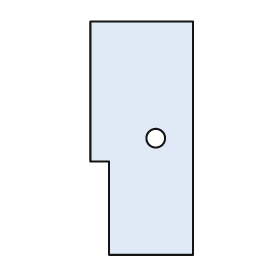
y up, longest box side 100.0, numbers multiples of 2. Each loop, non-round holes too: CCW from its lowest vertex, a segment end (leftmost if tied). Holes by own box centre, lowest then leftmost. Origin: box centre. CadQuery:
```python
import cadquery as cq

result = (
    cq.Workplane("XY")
    .moveTo(-14.0, -50.0)
    .lineTo(22.0, -50.0)
    .lineTo(22.0, 50.0)
    .lineTo(-22.0, 50.0)
    .lineTo(-22.0, -10.0)
    .lineTo(-14.0, -10.0)
    .close()
    .moveTo(6.0, 0.0)
    .circle(4.0)
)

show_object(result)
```